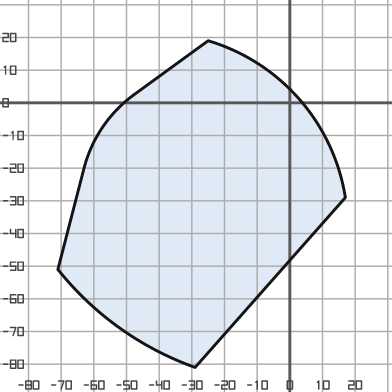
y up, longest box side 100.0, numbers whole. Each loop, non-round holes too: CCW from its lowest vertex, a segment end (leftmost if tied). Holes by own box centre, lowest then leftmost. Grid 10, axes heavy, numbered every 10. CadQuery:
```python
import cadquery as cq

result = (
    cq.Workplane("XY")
    .moveTo(-29.0, -81.0)
    .lineTo(17.0, -29.0)
    .threePointArc((3.0, 1.0), (-25.0, 19.0))
    .lineTo(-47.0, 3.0)
    .threePointArc((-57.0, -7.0), (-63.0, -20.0))
    .lineTo(-71.0, -51.0)
    .threePointArc((-52.0, -69.0), (-29.0, -81.0))
    .close()
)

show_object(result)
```